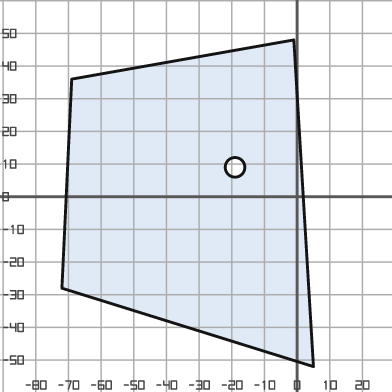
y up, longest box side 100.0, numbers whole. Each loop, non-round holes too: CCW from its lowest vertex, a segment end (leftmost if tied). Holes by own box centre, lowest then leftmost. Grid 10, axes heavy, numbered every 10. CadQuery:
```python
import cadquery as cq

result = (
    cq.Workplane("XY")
    .moveTo(5.0, -52.0)
    .lineTo(-1.0, 48.0)
    .lineTo(-69.0, 36.0)
    .lineTo(-72.0, -28.0)
    .close()
    .moveTo(-19.0, 9.0)
    .circle(3.0)
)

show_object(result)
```